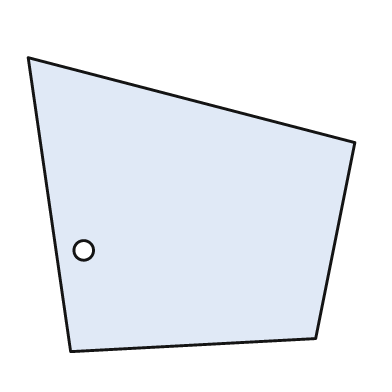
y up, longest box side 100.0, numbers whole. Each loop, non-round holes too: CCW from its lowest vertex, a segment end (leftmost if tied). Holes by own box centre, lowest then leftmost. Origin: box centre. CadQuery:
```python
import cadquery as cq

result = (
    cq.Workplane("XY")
    .moveTo(-37.0, -45.0)
    .lineTo(38.0, -41.0)
    .lineTo(50.0, 19.0)
    .lineTo(-50.0, 45.0)
    .close()
    .moveTo(-33.0, -14.0)
    .circle(3.0)
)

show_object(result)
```